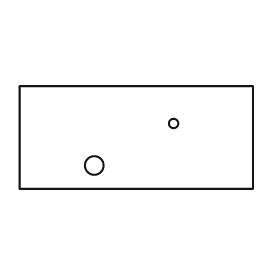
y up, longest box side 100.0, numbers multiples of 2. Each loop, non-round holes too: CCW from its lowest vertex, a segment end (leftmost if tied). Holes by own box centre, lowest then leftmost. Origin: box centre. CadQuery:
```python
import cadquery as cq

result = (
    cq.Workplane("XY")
    .moveTo(-50.0, -22.0)
    .lineTo(50.0, -22.0)
    .lineTo(50.0, 22.0)
    .lineTo(-50.0, 22.0)
    .close()
    .moveTo(-18.0, -12.0)
    .circle(4.0)
    .moveTo(16.0, 6.0)
    .circle(2.0)
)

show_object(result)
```